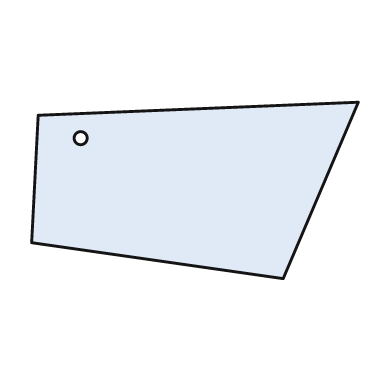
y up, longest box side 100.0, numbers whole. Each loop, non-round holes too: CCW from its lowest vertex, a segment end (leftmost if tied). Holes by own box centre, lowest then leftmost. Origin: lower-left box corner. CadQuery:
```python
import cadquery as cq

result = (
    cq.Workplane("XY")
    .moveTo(77.0, 0.0)
    .lineTo(100.0, 54.0)
    .lineTo(2.0, 50.0)
    .lineTo(0.0, 11.0)
    .close()
    .moveTo(15.0, 43.0)
    .circle(2.0)
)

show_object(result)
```